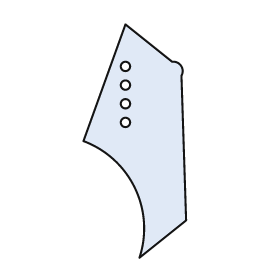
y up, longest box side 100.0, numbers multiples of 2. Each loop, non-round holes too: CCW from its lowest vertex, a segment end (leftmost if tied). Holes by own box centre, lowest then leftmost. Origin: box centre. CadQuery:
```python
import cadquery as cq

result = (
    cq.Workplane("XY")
    .moveTo(2.0, -50.0)
    .lineTo(22.0, -34.0)
    .lineTo(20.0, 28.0)
    .threePointArc((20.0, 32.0), (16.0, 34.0))
    .lineTo(-4.0, 50.0)
    .lineTo(-22.0, 0.0)
    .threePointArc((0.0, -20.0), (2.0, -50.0))
    .close()
    .moveTo(-4.0, 8.0)
    .circle(2.0)
    .moveTo(-4.0, 16.0)
    .circle(2.0)
    .moveTo(-4.0, 24.0)
    .circle(2.0)
    .moveTo(-4.0, 32.0)
    .circle(2.0)
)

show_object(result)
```